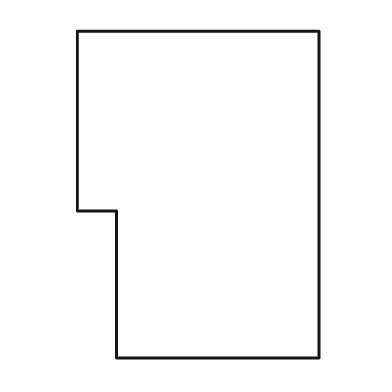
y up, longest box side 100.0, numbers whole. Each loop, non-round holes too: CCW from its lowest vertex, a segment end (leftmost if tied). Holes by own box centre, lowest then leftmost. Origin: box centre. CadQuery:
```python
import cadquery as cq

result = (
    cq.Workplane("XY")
    .moveTo(-25.0, -50.0)
    .lineTo(37.0, -50.0)
    .lineTo(37.0, 50.0)
    .lineTo(-37.0, 50.0)
    .lineTo(-37.0, -5.0)
    .lineTo(-25.0, -5.0)
    .close()
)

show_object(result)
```